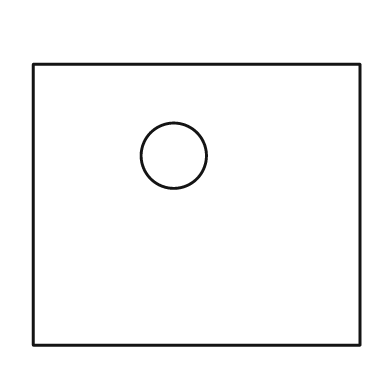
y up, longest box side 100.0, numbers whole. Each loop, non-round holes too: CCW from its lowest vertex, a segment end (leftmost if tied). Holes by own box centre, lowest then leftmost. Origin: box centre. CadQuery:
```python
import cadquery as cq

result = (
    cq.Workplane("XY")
    .moveTo(-50.0, -43.0)
    .lineTo(50.0, -43.0)
    .lineTo(50.0, 43.0)
    .lineTo(-50.0, 43.0)
    .close()
    .moveTo(-7.0, 15.0)
    .circle(10.0)
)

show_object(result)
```